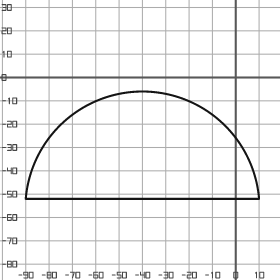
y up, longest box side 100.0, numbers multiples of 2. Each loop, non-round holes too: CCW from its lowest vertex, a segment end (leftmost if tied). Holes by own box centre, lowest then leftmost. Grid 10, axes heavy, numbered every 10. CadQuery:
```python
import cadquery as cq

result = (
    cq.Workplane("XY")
    .moveTo(-90.0, -52.0)
    .lineTo(10.0, -52.0)
    .threePointArc((-40.0, -6.0), (-90.0, -52.0))
    .close()
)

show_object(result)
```